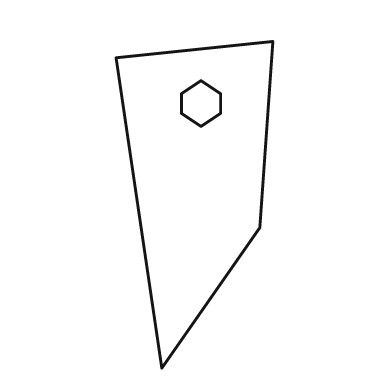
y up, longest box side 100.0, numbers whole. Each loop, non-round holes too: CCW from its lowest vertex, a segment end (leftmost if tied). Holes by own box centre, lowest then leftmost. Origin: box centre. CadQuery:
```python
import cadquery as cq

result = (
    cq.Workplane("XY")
    .moveTo(-10.0, -50.0)
    .lineTo(20.0, -7.0)
    .lineTo(24.0, 50.0)
    .lineTo(-24.0, 45.0)
    .close()
    .moveTo(2.0, 24.0)
    .lineTo(8.0, 28.0)
    .lineTo(8.0, 34.0)
    .lineTo(2.0, 38.0)
    .lineTo(-4.0, 34.0)
    .lineTo(-4.0, 28.0)
    .close()
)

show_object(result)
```